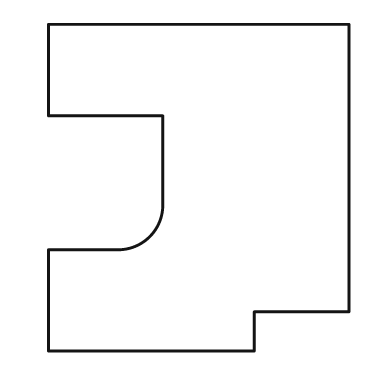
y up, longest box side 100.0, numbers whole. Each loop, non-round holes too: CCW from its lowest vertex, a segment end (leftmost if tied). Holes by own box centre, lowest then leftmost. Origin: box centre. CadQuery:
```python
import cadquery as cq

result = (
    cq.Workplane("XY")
    .moveTo(-46.0, -50.0)
    .lineTo(17.0, -50.0)
    .lineTo(17.0, -38.0)
    .lineTo(46.0, -38.0)
    .lineTo(46.0, 50.0)
    .lineTo(-46.0, 50.0)
    .lineTo(-46.0, 22.0)
    .lineTo(-11.0, 22.0)
    .lineTo(-11.0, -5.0)
    .threePointArc((-15.0, -15.0), (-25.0, -19.0))
    .lineTo(-46.0, -19.0)
    .close()
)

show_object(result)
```